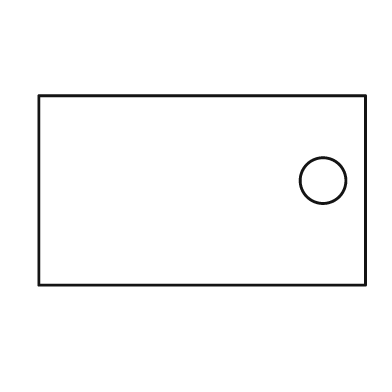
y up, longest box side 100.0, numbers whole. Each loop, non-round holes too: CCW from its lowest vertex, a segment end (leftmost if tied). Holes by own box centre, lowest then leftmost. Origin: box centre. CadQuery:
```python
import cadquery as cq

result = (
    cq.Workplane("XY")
    .moveTo(-50.0, -29.0)
    .lineTo(50.0, -29.0)
    .lineTo(50.0, 29.0)
    .lineTo(-50.0, 29.0)
    .close()
    .moveTo(37.0, 3.0)
    .circle(7.0)
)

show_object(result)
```